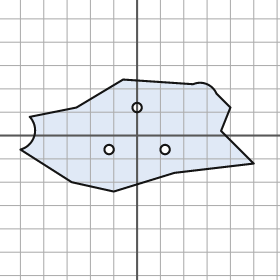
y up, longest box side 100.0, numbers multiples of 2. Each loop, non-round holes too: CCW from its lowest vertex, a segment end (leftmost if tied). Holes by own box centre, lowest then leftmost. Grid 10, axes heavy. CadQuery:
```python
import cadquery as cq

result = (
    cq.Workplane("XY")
    .moveTo(-10.0, -24.0)
    .lineTo(16.0, -16.0)
    .lineTo(50.0, -12.0)
    .lineTo(36.0, 2.0)
    .lineTo(40.0, 12.0)
    .lineTo(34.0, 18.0)
    .threePointArc((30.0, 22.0), (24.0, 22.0))
    .lineTo(-6.0, 24.0)
    .lineTo(-26.0, 12.0)
    .lineTo(-46.0, 8.0)
    .threePointArc((-44.0, 0.0), (-50.0, -6.0))
    .lineTo(-28.0, -20.0)
    .close()
    .moveTo(-12.0, -6.0)
    .circle(2.0)
    .moveTo(12.0, -6.0)
    .circle(2.0)
    .moveTo(0.0, 12.0)
    .circle(2.0)
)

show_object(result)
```